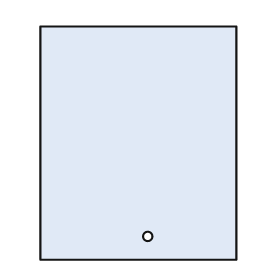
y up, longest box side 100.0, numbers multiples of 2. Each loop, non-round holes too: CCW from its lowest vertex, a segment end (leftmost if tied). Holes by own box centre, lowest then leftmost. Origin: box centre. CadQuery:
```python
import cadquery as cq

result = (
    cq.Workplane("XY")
    .moveTo(-42.0, -50.0)
    .lineTo(42.0, -50.0)
    .lineTo(42.0, 50.0)
    .lineTo(-42.0, 50.0)
    .close()
    .moveTo(4.0, -40.0)
    .circle(2.0)
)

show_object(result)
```